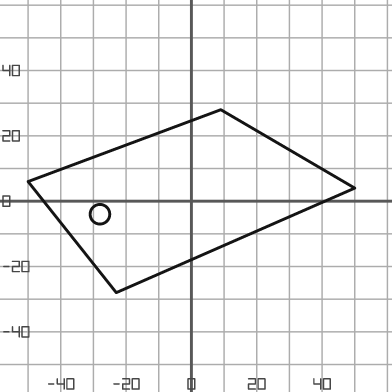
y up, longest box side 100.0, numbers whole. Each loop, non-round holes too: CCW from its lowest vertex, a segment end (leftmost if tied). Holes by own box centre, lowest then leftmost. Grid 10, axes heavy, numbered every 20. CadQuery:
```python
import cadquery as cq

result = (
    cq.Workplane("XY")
    .moveTo(-23.0, -28.0)
    .lineTo(50.0, 4.0)
    .lineTo(9.0, 28.0)
    .lineTo(-50.0, 6.0)
    .close()
    .moveTo(-28.0, -4.0)
    .circle(3.0)
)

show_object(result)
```